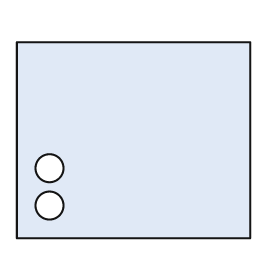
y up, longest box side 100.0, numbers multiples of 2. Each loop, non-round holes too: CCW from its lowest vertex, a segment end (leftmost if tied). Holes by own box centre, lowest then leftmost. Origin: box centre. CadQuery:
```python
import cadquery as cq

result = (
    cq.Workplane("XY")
    .moveTo(-50.0, -42.0)
    .lineTo(50.0, -42.0)
    .lineTo(50.0, 42.0)
    .lineTo(-50.0, 42.0)
    .close()
    .moveTo(-36.0, -28.0)
    .circle(6.0)
    .moveTo(-36.0, -12.0)
    .circle(6.0)
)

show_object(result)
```